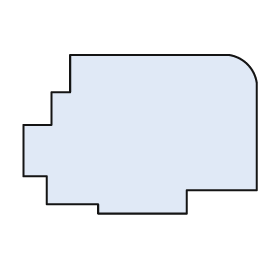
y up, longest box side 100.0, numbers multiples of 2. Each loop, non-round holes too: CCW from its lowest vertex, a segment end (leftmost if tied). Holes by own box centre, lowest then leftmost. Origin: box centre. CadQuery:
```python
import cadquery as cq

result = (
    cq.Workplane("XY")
    .moveTo(-18.0, -34.0)
    .lineTo(20.0, -34.0)
    .lineTo(20.0, -24.0)
    .lineTo(50.0, -24.0)
    .lineTo(50.0, 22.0)
    .threePointArc((46.0, 30.0), (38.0, 34.0))
    .lineTo(-30.0, 34.0)
    .lineTo(-30.0, 18.0)
    .lineTo(-38.0, 18.0)
    .lineTo(-38.0, 4.0)
    .lineTo(-50.0, 4.0)
    .lineTo(-50.0, -18.0)
    .lineTo(-40.0, -18.0)
    .lineTo(-40.0, -30.0)
    .lineTo(-18.0, -30.0)
    .close()
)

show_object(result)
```